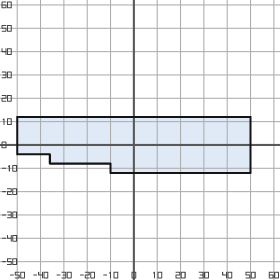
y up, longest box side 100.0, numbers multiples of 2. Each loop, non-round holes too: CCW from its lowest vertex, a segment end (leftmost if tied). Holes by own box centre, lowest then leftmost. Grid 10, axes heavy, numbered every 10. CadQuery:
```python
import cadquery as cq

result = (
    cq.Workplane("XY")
    .moveTo(-10.0, -12.0)
    .lineTo(50.0, -12.0)
    .lineTo(50.0, 12.0)
    .lineTo(-50.0, 12.0)
    .lineTo(-50.0, -4.0)
    .lineTo(-36.0, -4.0)
    .lineTo(-36.0, -8.0)
    .lineTo(-10.0, -8.0)
    .close()
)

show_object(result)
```